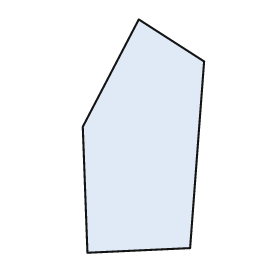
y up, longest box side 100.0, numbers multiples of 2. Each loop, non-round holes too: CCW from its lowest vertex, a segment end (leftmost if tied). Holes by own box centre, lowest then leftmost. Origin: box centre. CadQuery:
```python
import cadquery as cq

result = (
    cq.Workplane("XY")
    .moveTo(-24.0, -50.0)
    .lineTo(20.0, -48.0)
    .lineTo(26.0, 32.0)
    .lineTo(-2.0, 50.0)
    .lineTo(-26.0, 4.0)
    .close()
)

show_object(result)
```